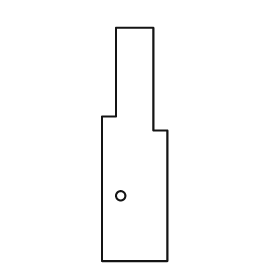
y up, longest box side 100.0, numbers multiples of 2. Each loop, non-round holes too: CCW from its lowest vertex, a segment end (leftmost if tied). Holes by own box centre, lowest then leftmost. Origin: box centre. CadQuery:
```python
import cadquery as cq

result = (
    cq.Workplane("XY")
    .moveTo(-14.0, -50.0)
    .lineTo(14.0, -50.0)
    .lineTo(14.0, 6.0)
    .lineTo(8.0, 6.0)
    .lineTo(8.0, 50.0)
    .lineTo(-8.0, 50.0)
    .lineTo(-8.0, 12.0)
    .lineTo(-14.0, 12.0)
    .close()
    .moveTo(-6.0, -22.0)
    .circle(2.0)
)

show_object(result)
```